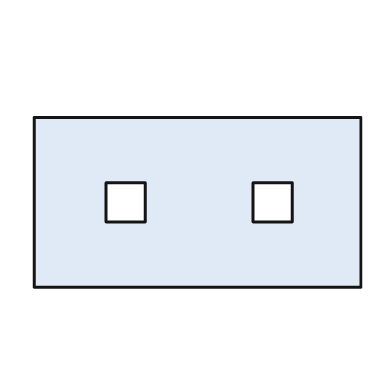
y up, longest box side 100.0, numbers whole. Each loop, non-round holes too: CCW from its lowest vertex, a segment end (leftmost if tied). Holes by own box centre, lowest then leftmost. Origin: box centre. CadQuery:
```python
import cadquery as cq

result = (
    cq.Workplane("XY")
    .moveTo(-50.0, -26.0)
    .lineTo(50.0, -26.0)
    .lineTo(50.0, 26.0)
    .lineTo(-50.0, 26.0)
    .close()
    .moveTo(-28.0, -6.0)
    .lineTo(-16.0, -6.0)
    .lineTo(-16.0, 6.0)
    .lineTo(-28.0, 6.0)
    .close()
    .moveTo(17.0, -6.0)
    .lineTo(29.0, -6.0)
    .lineTo(29.0, 6.0)
    .lineTo(17.0, 6.0)
    .close()
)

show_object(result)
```